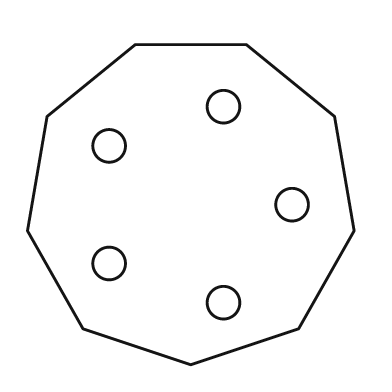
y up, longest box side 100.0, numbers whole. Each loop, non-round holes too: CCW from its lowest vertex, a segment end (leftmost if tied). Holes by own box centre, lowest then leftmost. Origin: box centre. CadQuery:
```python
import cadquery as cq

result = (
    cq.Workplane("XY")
    .moveTo(0.0, -49.0)
    .lineTo(33.0, -38.0)
    .lineTo(50.0, -8.0)
    .lineTo(44.0, 27.0)
    .lineTo(17.0, 49.0)
    .lineTo(-17.0, 49.0)
    .lineTo(-44.0, 27.0)
    .lineTo(-50.0, -8.0)
    .lineTo(-33.0, -38.0)
    .close()
    .moveTo(10.0, -30.0)
    .circle(5.0)
    .moveTo(-25.0, -18.0)
    .circle(5.0)
    .moveTo(31.0, 0.0)
    .circle(5.0)
    .moveTo(-25.0, 18.0)
    .circle(5.0)
    .moveTo(10.0, 30.0)
    .circle(5.0)
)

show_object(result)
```